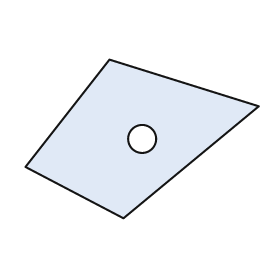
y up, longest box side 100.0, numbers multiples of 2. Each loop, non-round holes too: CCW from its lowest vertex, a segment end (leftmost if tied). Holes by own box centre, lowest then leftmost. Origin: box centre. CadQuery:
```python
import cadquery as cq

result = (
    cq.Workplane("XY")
    .moveTo(-8.0, -34.0)
    .lineTo(50.0, 14.0)
    .lineTo(-14.0, 34.0)
    .lineTo(-50.0, -12.0)
    .close()
    .moveTo(0.0, 0.0)
    .circle(6.0)
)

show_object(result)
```